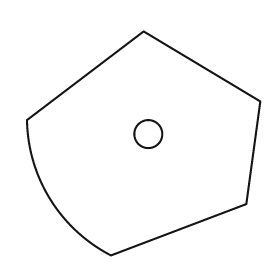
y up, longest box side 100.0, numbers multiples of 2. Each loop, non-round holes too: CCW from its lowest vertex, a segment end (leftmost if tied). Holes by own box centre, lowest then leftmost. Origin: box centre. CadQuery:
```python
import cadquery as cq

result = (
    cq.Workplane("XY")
    .moveTo(-14.0, -48.0)
    .lineTo(44.0, -26.0)
    .lineTo(50.0, 18.0)
    .lineTo(0.0, 48.0)
    .lineTo(-50.0, 10.0)
    .threePointArc((-40.0, -24.0), (-14.0, -48.0))
    .close()
    .moveTo(2.0, 4.0)
    .circle(6.0)
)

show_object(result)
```